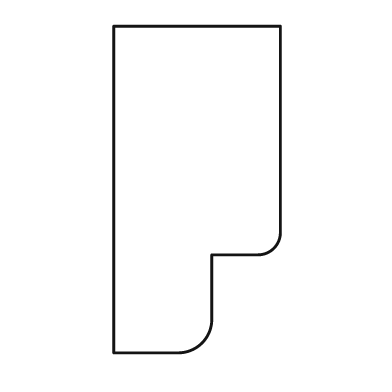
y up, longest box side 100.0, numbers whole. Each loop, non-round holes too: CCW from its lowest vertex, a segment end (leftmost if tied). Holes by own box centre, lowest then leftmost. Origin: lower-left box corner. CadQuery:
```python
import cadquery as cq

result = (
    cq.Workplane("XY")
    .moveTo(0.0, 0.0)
    .lineTo(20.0, 0.0)
    .threePointArc((27.0, 3.0), (30.0, 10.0))
    .lineTo(30.0, 30.0)
    .lineTo(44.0, 30.0)
    .threePointArc((49.0, 32.0), (51.0, 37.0))
    .lineTo(51.0, 100.0)
    .lineTo(0.0, 100.0)
    .close()
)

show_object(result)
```